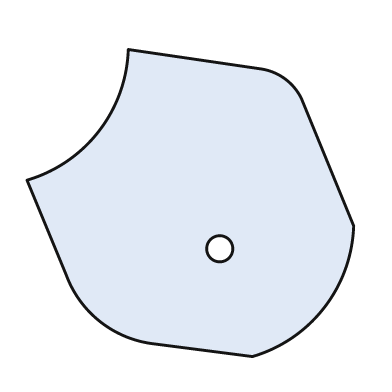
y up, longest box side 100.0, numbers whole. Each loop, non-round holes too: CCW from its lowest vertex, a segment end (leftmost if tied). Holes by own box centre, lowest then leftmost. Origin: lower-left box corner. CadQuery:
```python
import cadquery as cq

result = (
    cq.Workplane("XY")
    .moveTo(69.0, 0.0)
    .threePointArc((91.0, 15.0), (100.0, 40.0))
    .lineTo(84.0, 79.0)
    .threePointArc((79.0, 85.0), (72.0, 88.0))
    .lineTo(31.0, 94.0)
    .threePointArc((22.0, 69.0), (0.0, 54.0))
    .lineTo(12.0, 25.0)
    .threePointArc((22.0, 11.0), (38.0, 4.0))
    .close()
    .moveTo(59.0, 33.0)
    .circle(4.0)
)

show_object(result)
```